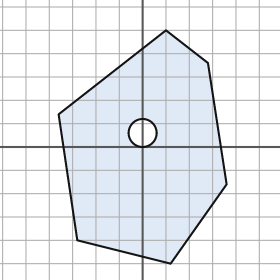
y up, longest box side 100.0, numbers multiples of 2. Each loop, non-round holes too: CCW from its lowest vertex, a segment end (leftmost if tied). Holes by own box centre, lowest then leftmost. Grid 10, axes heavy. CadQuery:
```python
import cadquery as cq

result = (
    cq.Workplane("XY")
    .moveTo(12.0, -50.0)
    .lineTo(36.0, -16.0)
    .lineTo(28.0, 36.0)
    .lineTo(10.0, 50.0)
    .lineTo(-36.0, 14.0)
    .lineTo(-28.0, -40.0)
    .close()
    .moveTo(0.0, 6.0)
    .circle(6.0)
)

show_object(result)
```